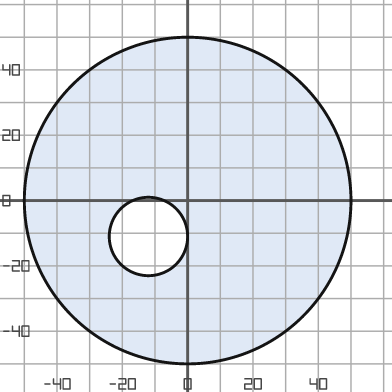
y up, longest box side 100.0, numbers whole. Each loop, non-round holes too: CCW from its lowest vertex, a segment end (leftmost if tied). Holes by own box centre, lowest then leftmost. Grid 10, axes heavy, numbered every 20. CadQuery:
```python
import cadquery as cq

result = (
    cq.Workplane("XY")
    .moveTo(0.0, 0.0)
    .circle(50.0)
    .moveTo(-12.0, -11.0)
    .circle(12.0)
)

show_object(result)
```